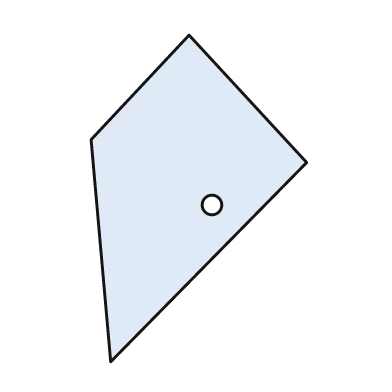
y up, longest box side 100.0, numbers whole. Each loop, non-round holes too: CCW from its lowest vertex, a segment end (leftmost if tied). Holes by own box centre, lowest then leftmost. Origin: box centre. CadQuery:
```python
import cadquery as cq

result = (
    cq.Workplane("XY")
    .moveTo(-27.0, -50.0)
    .lineTo(33.0, 11.0)
    .lineTo(-3.0, 50.0)
    .lineTo(-33.0, 18.0)
    .close()
    .moveTo(4.0, -2.0)
    .circle(3.0)
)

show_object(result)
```